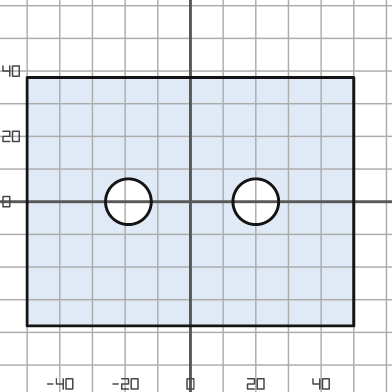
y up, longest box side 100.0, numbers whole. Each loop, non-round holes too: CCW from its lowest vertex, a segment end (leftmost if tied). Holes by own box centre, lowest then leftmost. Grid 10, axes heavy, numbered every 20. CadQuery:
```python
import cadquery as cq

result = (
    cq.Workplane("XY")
    .moveTo(-50.0, -38.0)
    .lineTo(50.0, -38.0)
    .lineTo(50.0, 38.0)
    .lineTo(-50.0, 38.0)
    .close()
    .moveTo(-19.0, 0.0)
    .circle(7.0)
    .moveTo(20.0, 0.0)
    .circle(7.0)
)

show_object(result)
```